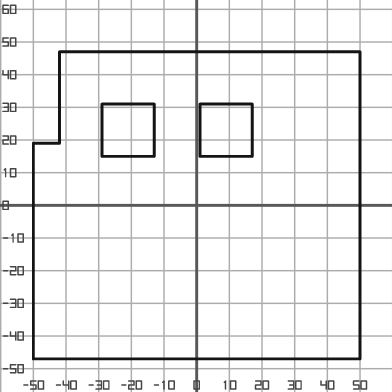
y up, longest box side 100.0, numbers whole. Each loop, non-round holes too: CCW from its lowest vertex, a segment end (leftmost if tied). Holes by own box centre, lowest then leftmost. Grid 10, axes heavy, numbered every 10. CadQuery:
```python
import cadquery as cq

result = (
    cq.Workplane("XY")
    .moveTo(-50.0, -47.0)
    .lineTo(50.0, -47.0)
    .lineTo(50.0, 47.0)
    .lineTo(-42.0, 47.0)
    .lineTo(-42.0, 19.0)
    .lineTo(-50.0, 19.0)
    .close()
    .moveTo(-29.0, 15.0)
    .lineTo(-13.0, 15.0)
    .lineTo(-13.0, 31.0)
    .lineTo(-29.0, 31.0)
    .close()
    .moveTo(1.0, 15.0)
    .lineTo(17.0, 15.0)
    .lineTo(17.0, 31.0)
    .lineTo(1.0, 31.0)
    .close()
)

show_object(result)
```